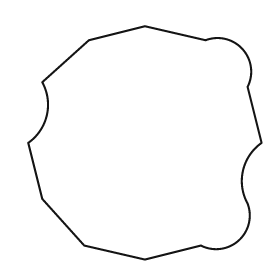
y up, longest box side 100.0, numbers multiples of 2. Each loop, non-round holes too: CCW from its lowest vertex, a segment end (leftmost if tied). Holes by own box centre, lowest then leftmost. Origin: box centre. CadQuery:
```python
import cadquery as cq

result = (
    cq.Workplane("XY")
    .moveTo(0.0, -50.0)
    .lineTo(24.0, -44.0)
    .threePointArc((40.0, -42.0), (44.0, -26.0))
    .threePointArc((42.0, -12.0), (50.0, 0.0))
    .lineTo(44.0, 24.0)
    .threePointArc((42.0, 40.0), (26.0, 44.0))
    .lineTo(0.0, 50.0)
    .lineTo(-24.0, 44.0)
    .lineTo(-44.0, 26.0)
    .threePointArc((-42.0, 12.0), (-50.0, 0.0))
    .lineTo(-44.0, -24.0)
    .lineTo(-26.0, -44.0)
    .close()
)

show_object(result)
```